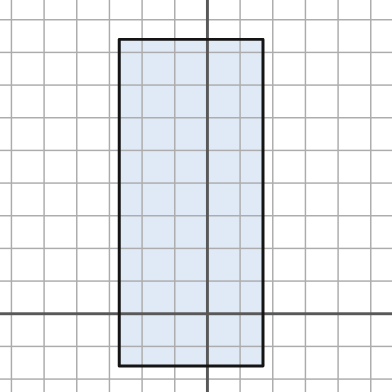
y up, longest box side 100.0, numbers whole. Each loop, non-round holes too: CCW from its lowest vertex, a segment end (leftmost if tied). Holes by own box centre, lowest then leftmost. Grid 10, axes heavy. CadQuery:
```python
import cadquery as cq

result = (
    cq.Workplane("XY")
    .moveTo(-27.0, -16.0)
    .lineTo(17.0, -16.0)
    .lineTo(17.0, 84.0)
    .lineTo(-27.0, 84.0)
    .close()
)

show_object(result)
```